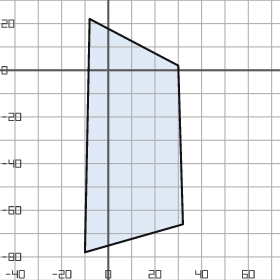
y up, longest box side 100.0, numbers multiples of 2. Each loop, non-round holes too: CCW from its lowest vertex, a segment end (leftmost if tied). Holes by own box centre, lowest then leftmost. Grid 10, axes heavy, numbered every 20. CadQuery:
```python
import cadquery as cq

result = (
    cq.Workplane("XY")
    .moveTo(-10.0, -78.0)
    .lineTo(32.0, -66.0)
    .lineTo(30.0, 2.0)
    .lineTo(-8.0, 22.0)
    .close()
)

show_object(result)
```